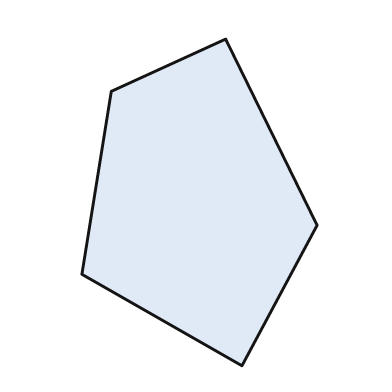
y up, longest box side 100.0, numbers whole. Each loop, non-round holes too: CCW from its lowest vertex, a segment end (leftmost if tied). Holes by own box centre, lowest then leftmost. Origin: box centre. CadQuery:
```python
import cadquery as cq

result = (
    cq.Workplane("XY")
    .moveTo(13.0, -50.0)
    .lineTo(36.0, -7.0)
    .lineTo(8.0, 50.0)
    .lineTo(-27.0, 34.0)
    .lineTo(-36.0, -22.0)
    .close()
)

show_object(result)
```